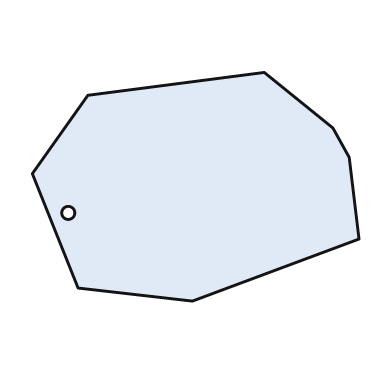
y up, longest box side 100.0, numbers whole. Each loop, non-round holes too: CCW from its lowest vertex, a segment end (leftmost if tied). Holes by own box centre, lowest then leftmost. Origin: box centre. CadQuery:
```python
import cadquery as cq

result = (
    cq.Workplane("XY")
    .moveTo(-1.0, -35.0)
    .lineTo(50.0, -16.0)
    .lineTo(47.0, 9.0)
    .lineTo(42.0, 18.0)
    .lineTo(21.0, 35.0)
    .lineTo(-33.0, 28.0)
    .lineTo(-50.0, 4.0)
    .lineTo(-36.0, -31.0)
    .close()
    .moveTo(-39.0, -8.0)
    .circle(2.0)
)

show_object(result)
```